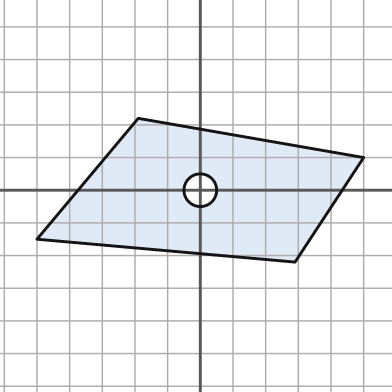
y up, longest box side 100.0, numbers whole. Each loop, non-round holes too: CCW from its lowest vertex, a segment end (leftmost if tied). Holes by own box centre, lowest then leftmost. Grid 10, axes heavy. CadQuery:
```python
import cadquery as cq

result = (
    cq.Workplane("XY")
    .moveTo(29.0, -22.0)
    .lineTo(50.0, 10.0)
    .lineTo(-19.0, 22.0)
    .lineTo(-50.0, -15.0)
    .close()
    .moveTo(0.0, 0.0)
    .circle(5.0)
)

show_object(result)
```